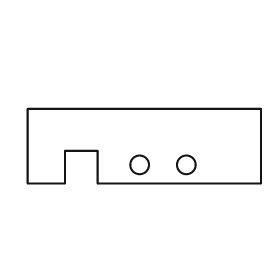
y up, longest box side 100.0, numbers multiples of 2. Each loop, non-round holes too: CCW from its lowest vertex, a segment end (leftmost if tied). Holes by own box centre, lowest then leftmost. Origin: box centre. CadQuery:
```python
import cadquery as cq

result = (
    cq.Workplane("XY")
    .moveTo(-50.0, -16.0)
    .lineTo(-34.0, -16.0)
    .lineTo(-34.0, -2.0)
    .lineTo(-20.0, -2.0)
    .lineTo(-20.0, -16.0)
    .lineTo(50.0, -16.0)
    .lineTo(50.0, 16.0)
    .lineTo(-50.0, 16.0)
    .close()
    .moveTo(-2.0, -8.0)
    .circle(4.0)
    .moveTo(18.0, -8.0)
    .circle(4.0)
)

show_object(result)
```